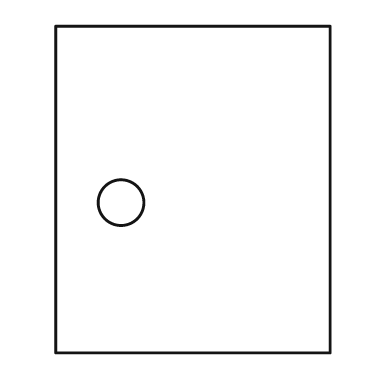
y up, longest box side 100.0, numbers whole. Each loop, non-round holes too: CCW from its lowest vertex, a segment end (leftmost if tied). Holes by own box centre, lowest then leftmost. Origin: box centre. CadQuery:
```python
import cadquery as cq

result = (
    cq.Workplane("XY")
    .moveTo(-42.0, -50.0)
    .lineTo(42.0, -50.0)
    .lineTo(42.0, 50.0)
    .lineTo(-42.0, 50.0)
    .close()
    .moveTo(-22.0, -4.0)
    .circle(7.0)
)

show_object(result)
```